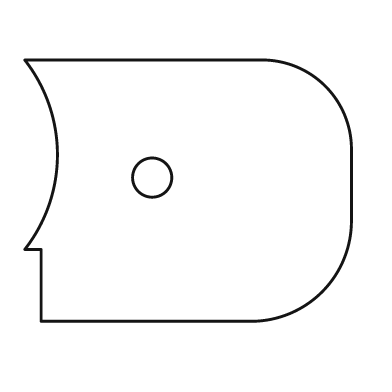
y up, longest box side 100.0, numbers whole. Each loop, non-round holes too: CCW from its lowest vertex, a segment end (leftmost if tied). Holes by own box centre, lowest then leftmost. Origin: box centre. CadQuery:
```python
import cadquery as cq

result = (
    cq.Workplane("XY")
    .moveTo(-45.0, -40.0)
    .lineTo(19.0, -40.0)
    .threePointArc((41.0, -31.0), (50.0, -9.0))
    .lineTo(50.0, 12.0)
    .threePointArc((42.0, 32.0), (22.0, 40.0))
    .lineTo(-50.0, 40.0)
    .threePointArc((-40.0, 11.0), (-50.0, -18.0))
    .lineTo(-45.0, -18.0)
    .close()
    .moveTo(-11.0, 4.0)
    .circle(6.0)
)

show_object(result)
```